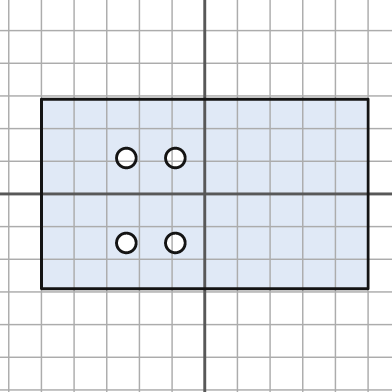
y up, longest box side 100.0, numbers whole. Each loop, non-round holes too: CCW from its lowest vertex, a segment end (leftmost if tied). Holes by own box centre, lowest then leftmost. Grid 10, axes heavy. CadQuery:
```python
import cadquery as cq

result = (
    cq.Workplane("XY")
    .moveTo(-50.0, -29.0)
    .lineTo(50.0, -29.0)
    .lineTo(50.0, 29.0)
    .lineTo(-50.0, 29.0)
    .close()
    .moveTo(-24.0, -15.0)
    .circle(3.0)
    .moveTo(-9.0, -15.0)
    .circle(3.0)
    .moveTo(-24.0, 11.0)
    .circle(3.0)
    .moveTo(-9.0, 11.0)
    .circle(3.0)
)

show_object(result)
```